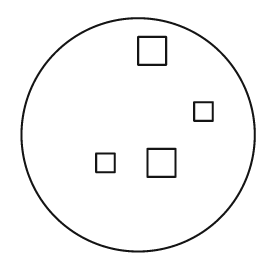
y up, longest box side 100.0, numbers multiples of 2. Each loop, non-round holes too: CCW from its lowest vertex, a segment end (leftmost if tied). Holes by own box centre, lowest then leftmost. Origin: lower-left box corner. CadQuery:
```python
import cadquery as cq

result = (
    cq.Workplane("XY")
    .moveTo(50.0, 50.0)
    .circle(50.0)
    .moveTo(32.0, 34.0)
    .lineTo(40.0, 34.0)
    .lineTo(40.0, 42.0)
    .lineTo(32.0, 42.0)
    .close()
    .moveTo(54.0, 32.0)
    .lineTo(66.0, 32.0)
    .lineTo(66.0, 44.0)
    .lineTo(54.0, 44.0)
    .close()
    .moveTo(74.0, 56.0)
    .lineTo(82.0, 56.0)
    .lineTo(82.0, 64.0)
    .lineTo(74.0, 64.0)
    .close()
    .moveTo(50.0, 80.0)
    .lineTo(62.0, 80.0)
    .lineTo(62.0, 92.0)
    .lineTo(50.0, 92.0)
    .close()
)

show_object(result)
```